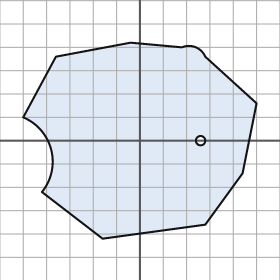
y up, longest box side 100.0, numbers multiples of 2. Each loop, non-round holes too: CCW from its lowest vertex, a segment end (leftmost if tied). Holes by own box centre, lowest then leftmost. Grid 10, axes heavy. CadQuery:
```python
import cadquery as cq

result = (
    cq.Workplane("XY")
    .moveTo(-16.0, -42.0)
    .lineTo(28.0, -36.0)
    .lineTo(44.0, -14.0)
    .lineTo(50.0, 16.0)
    .lineTo(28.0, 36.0)
    .threePointArc((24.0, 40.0), (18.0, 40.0))
    .lineTo(-4.0, 42.0)
    .lineTo(-36.0, 36.0)
    .lineTo(-50.0, 10.0)
    .threePointArc((-38.0, -4.0), (-42.0, -22.0))
    .close()
    .moveTo(26.0, 0.0)
    .circle(2.0)
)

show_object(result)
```